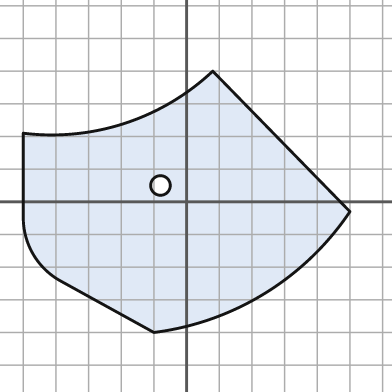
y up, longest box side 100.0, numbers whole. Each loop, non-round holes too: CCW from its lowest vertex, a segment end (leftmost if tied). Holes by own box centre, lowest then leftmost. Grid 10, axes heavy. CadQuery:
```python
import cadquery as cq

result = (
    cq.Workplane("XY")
    .moveTo(-10.0, -40.0)
    .threePointArc((24.0, -28.0), (50.0, -3.0))
    .lineTo(8.0, 40.0)
    .threePointArc((-19.0, 24.0), (-50.0, 21.0))
    .lineTo(-50.0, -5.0)
    .threePointArc((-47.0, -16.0), (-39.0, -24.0))
    .close()
    .moveTo(-8.0, 5.0)
    .circle(3.0)
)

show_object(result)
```